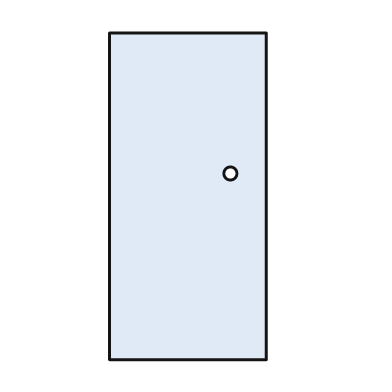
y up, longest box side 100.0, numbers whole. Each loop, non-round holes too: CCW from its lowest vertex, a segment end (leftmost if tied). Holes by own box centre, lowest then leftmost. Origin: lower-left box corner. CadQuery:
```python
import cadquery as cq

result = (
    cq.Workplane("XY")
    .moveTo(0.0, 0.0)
    .lineTo(48.0, 0.0)
    .lineTo(48.0, 100.0)
    .lineTo(0.0, 100.0)
    .close()
    .moveTo(37.0, 57.0)
    .circle(2.0)
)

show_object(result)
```